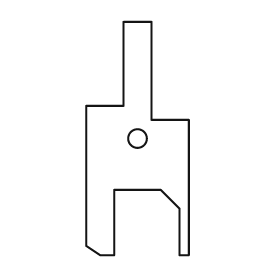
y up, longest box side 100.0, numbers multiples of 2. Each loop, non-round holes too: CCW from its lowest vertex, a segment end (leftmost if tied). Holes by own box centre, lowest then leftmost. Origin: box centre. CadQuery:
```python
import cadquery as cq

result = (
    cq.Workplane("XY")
    .moveTo(-16.0, -50.0)
    .lineTo(-10.0, -50.0)
    .lineTo(-10.0, -22.0)
    .lineTo(10.0, -22.0)
    .lineTo(18.0, -30.0)
    .lineTo(18.0, -50.0)
    .lineTo(22.0, -50.0)
    .lineTo(22.0, 8.0)
    .lineTo(6.0, 8.0)
    .lineTo(6.0, 50.0)
    .lineTo(-6.0, 50.0)
    .lineTo(-6.0, 14.0)
    .lineTo(-22.0, 14.0)
    .lineTo(-22.0, -46.0)
    .close()
    .moveTo(0.0, 0.0)
    .circle(4.0)
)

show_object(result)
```